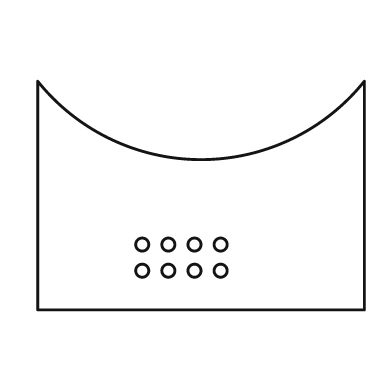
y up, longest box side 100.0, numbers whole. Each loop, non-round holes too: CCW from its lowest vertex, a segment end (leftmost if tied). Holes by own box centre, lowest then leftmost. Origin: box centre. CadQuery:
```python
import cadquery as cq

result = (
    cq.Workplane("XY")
    .moveTo(-50.0, -35.0)
    .lineTo(50.0, -35.0)
    .lineTo(50.0, 35.0)
    .threePointArc((0.0, 11.0), (-50.0, 35.0))
    .close()
    .moveTo(-18.0, -23.0)
    .circle(2.0)
    .moveTo(-10.0, -23.0)
    .circle(2.0)
    .moveTo(-2.0, -23.0)
    .circle(2.0)
    .moveTo(6.0, -23.0)
    .circle(2.0)
    .moveTo(-18.0, -15.0)
    .circle(2.0)
    .moveTo(-10.0, -15.0)
    .circle(2.0)
    .moveTo(-2.0, -15.0)
    .circle(2.0)
    .moveTo(6.0, -15.0)
    .circle(2.0)
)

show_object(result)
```